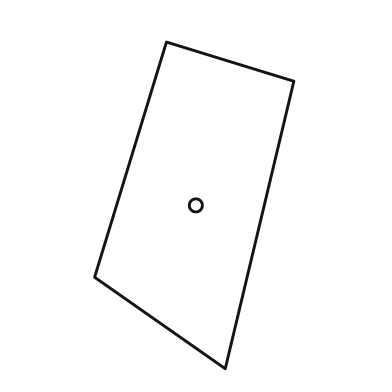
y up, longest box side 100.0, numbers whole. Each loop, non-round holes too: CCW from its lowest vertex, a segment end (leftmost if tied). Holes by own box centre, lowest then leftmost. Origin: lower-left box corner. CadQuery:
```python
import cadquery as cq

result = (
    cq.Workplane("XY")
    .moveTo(40.0, 0.0)
    .lineTo(61.0, 88.0)
    .lineTo(22.0, 100.0)
    .lineTo(0.0, 28.0)
    .close()
    .moveTo(31.0, 50.0)
    .circle(2.0)
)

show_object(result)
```